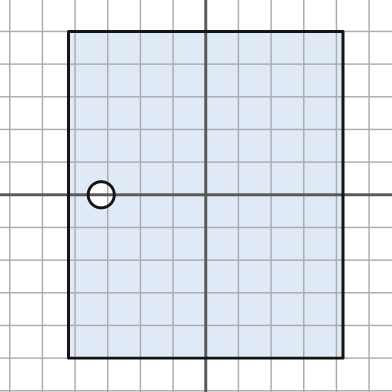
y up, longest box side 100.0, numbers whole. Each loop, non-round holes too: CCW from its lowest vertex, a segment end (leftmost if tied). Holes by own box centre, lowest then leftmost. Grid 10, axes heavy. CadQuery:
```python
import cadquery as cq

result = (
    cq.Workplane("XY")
    .moveTo(-42.0, -50.0)
    .lineTo(42.0, -50.0)
    .lineTo(42.0, 50.0)
    .lineTo(-42.0, 50.0)
    .close()
    .moveTo(-32.0, 0.0)
    .circle(4.0)
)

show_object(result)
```